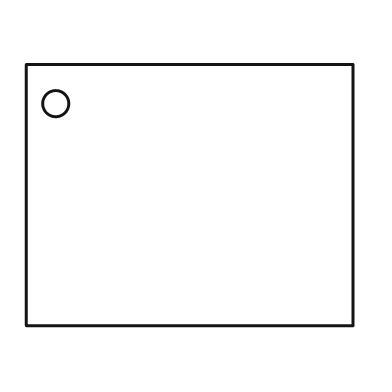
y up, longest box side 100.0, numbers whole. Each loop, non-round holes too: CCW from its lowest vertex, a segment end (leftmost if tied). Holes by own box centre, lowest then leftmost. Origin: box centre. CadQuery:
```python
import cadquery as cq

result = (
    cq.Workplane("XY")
    .moveTo(-50.0, -40.0)
    .lineTo(50.0, -40.0)
    .lineTo(50.0, 40.0)
    .lineTo(-50.0, 40.0)
    .close()
    .moveTo(-41.0, 28.0)
    .circle(4.0)
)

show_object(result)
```